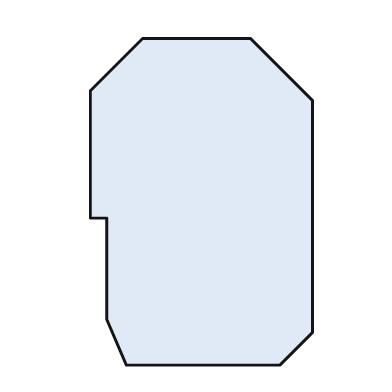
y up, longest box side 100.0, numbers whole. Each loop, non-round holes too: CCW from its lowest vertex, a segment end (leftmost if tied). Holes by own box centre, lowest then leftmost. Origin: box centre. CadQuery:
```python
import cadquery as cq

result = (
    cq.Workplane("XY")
    .moveTo(-23.0, -50.0)
    .lineTo(24.0, -50.0)
    .lineTo(34.0, -40.0)
    .lineTo(34.0, 31.0)
    .lineTo(15.0, 50.0)
    .lineTo(-18.0, 50.0)
    .lineTo(-34.0, 34.0)
    .lineTo(-34.0, -5.0)
    .lineTo(-29.0, -5.0)
    .lineTo(-29.0, -36.0)
    .close()
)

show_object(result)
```